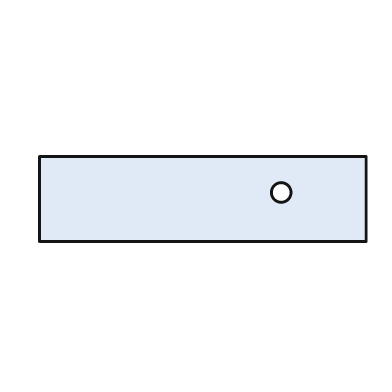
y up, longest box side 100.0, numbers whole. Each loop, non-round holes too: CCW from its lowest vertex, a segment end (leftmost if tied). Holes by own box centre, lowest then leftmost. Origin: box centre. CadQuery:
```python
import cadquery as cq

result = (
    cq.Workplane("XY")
    .moveTo(-50.0, -13.0)
    .lineTo(50.0, -13.0)
    .lineTo(50.0, 13.0)
    .lineTo(-50.0, 13.0)
    .close()
    .moveTo(24.0, 2.0)
    .circle(3.0)
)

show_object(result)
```